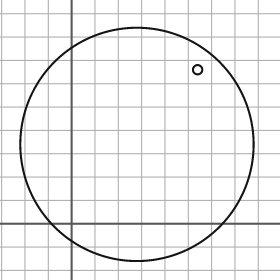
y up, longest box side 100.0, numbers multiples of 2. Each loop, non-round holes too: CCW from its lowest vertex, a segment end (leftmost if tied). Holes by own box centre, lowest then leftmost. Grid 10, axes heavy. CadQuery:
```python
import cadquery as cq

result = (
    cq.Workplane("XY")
    .moveTo(28.0, 34.0)
    .circle(50.0)
    .moveTo(54.0, 66.0)
    .circle(2.0)
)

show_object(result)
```